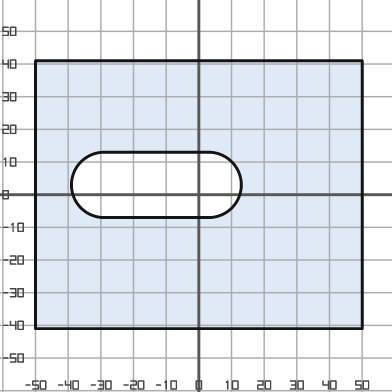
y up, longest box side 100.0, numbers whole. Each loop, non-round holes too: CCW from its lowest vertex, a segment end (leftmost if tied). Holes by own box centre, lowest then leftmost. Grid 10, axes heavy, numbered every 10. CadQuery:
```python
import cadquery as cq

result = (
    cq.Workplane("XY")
    .moveTo(-50.0, -41.0)
    .lineTo(50.0, -41.0)
    .lineTo(50.0, 41.0)
    .lineTo(-50.0, 41.0)
    .close()
    .moveTo(-29.0, -7.0)
    .lineTo(3.0, -7.0)
    .threePointArc((13.0, 3.0), (3.0, 13.0))
    .lineTo(-29.0, 13.0)
    .threePointArc((-39.0, 3.0), (-29.0, -7.0))
    .close()
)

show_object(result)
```